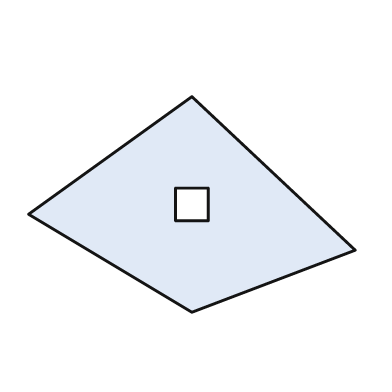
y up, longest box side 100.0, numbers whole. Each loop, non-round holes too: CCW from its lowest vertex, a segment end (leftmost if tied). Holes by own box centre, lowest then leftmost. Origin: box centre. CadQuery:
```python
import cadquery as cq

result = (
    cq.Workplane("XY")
    .moveTo(0.0, -33.0)
    .lineTo(50.0, -14.0)
    .lineTo(0.0, 33.0)
    .lineTo(-50.0, -3.0)
    .close()
    .moveTo(-5.0, -5.0)
    .lineTo(5.0, -5.0)
    .lineTo(5.0, 5.0)
    .lineTo(-5.0, 5.0)
    .close()
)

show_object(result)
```